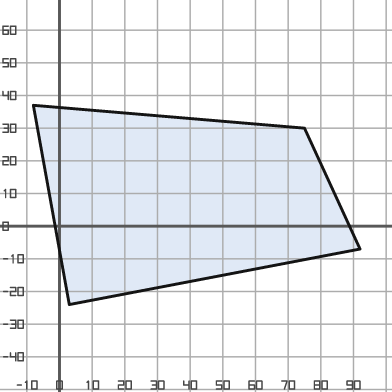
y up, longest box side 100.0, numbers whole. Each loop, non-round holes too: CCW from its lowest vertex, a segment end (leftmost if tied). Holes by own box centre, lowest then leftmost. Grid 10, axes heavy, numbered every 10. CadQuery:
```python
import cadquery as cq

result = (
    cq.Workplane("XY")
    .moveTo(3.0, -24.0)
    .lineTo(92.0, -7.0)
    .lineTo(75.0, 30.0)
    .lineTo(-8.0, 37.0)
    .close()
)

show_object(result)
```